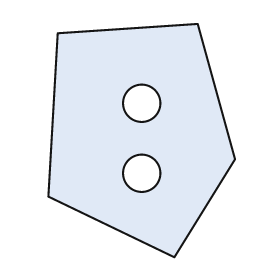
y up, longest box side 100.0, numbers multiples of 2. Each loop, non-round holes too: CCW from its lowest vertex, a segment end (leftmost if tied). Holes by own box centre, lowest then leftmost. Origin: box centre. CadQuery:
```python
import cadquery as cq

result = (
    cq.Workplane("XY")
    .moveTo(14.0, -50.0)
    .lineTo(40.0, -8.0)
    .lineTo(24.0, 50.0)
    .lineTo(-36.0, 46.0)
    .lineTo(-40.0, -24.0)
    .close()
    .moveTo(0.0, -14.0)
    .circle(8.0)
    .moveTo(0.0, 16.0)
    .circle(8.0)
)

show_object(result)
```